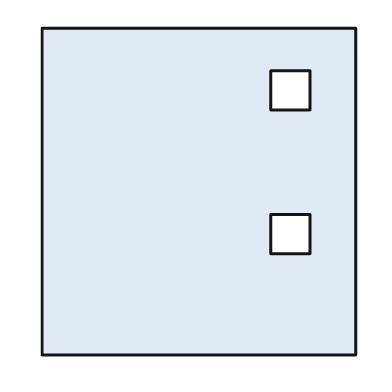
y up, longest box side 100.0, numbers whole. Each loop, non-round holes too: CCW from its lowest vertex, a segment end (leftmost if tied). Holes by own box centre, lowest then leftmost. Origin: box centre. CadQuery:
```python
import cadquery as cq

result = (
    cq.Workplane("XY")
    .moveTo(-48.0, -50.0)
    .lineTo(48.0, -50.0)
    .lineTo(48.0, 50.0)
    .lineTo(-48.0, 50.0)
    .close()
    .moveTo(22.0, -19.0)
    .lineTo(34.0, -19.0)
    .lineTo(34.0, -7.0)
    .lineTo(22.0, -7.0)
    .close()
    .moveTo(22.0, 25.0)
    .lineTo(34.0, 25.0)
    .lineTo(34.0, 37.0)
    .lineTo(22.0, 37.0)
    .close()
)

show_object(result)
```